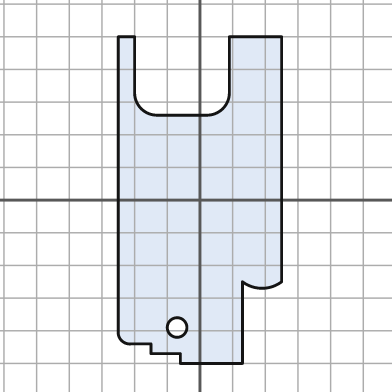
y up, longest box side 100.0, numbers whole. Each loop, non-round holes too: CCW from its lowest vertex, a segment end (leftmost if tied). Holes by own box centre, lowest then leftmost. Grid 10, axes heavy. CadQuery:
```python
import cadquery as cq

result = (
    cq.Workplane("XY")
    .moveTo(-6.0, -50.0)
    .lineTo(13.0, -50.0)
    .lineTo(13.0, -25.0)
    .threePointArc((19.0, -27.0), (25.0, -25.0))
    .lineTo(25.0, 50.0)
    .lineTo(9.0, 50.0)
    .lineTo(9.0, 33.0)
    .threePointArc((7.0, 28.0), (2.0, 26.0))
    .lineTo(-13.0, 26.0)
    .threePointArc((-18.0, 28.0), (-20.0, 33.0))
    .lineTo(-20.0, 50.0)
    .lineTo(-25.0, 50.0)
    .lineTo(-25.0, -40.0)
    .threePointArc((-24.0, -43.0), (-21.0, -44.0))
    .lineTo(-15.0, -44.0)
    .lineTo(-15.0, -47.0)
    .lineTo(-6.0, -47.0)
    .close()
    .moveTo(-7.0, -39.0)
    .circle(3.0)
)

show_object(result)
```